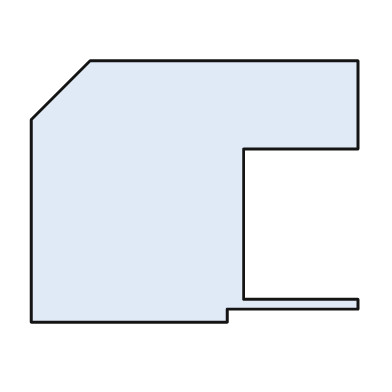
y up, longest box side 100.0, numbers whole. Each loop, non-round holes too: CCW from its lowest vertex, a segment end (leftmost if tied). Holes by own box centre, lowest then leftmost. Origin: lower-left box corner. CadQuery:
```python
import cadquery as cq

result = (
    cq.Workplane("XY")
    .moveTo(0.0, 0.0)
    .lineTo(60.0, 0.0)
    .lineTo(60.0, 4.0)
    .lineTo(100.0, 4.0)
    .lineTo(100.0, 7.0)
    .lineTo(65.0, 7.0)
    .lineTo(65.0, 53.0)
    .lineTo(100.0, 53.0)
    .lineTo(100.0, 80.0)
    .lineTo(18.0, 80.0)
    .lineTo(0.0, 62.0)
    .close()
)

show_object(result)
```